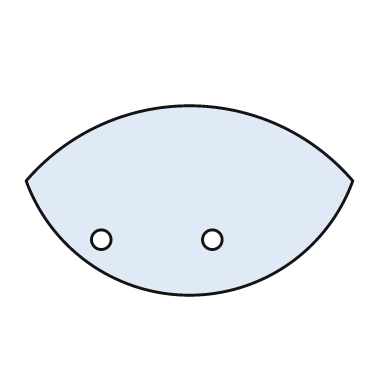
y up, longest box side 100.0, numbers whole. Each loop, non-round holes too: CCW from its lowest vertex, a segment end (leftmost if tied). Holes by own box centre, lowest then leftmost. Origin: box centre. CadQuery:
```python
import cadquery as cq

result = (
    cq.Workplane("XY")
    .moveTo(-50.0, 6.0)
    .threePointArc((0.0, -29.0), (50.0, 6.0))
    .threePointArc((0.0, 29.0), (-50.0, 6.0))
    .close()
    .moveTo(-27.0, -12.0)
    .circle(3.0)
    .moveTo(7.0, -12.0)
    .circle(3.0)
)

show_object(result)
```